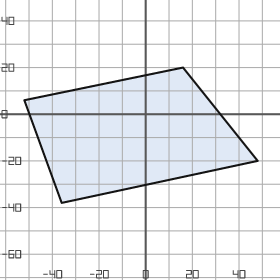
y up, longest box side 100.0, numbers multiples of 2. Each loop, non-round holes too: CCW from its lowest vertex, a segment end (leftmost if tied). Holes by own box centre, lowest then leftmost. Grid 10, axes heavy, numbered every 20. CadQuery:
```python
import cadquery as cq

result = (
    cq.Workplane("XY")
    .moveTo(-36.0, -38.0)
    .lineTo(48.0, -20.0)
    .lineTo(16.0, 20.0)
    .lineTo(-52.0, 6.0)
    .close()
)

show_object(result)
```